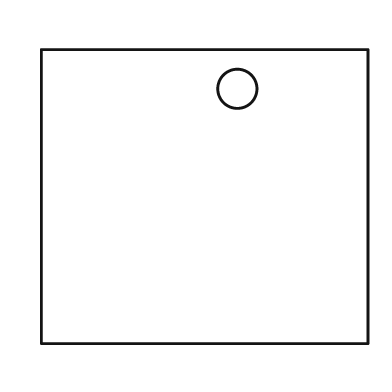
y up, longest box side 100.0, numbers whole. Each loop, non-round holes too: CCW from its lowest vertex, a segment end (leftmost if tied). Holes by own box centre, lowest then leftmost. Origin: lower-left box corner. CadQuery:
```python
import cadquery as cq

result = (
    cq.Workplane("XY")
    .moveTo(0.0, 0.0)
    .lineTo(100.0, 0.0)
    .lineTo(100.0, 90.0)
    .lineTo(0.0, 90.0)
    .close()
    .moveTo(60.0, 78.0)
    .circle(6.0)
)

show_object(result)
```